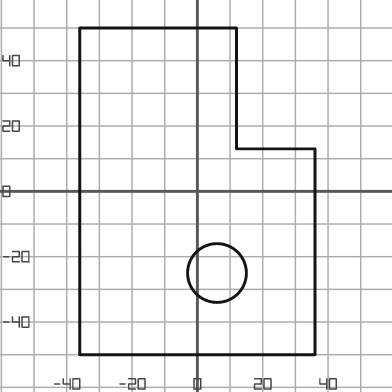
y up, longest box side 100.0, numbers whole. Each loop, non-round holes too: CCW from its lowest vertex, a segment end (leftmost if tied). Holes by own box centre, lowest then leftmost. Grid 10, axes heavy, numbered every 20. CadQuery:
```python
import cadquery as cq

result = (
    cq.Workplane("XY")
    .moveTo(-36.0, -50.0)
    .lineTo(36.0, -50.0)
    .lineTo(36.0, 13.0)
    .lineTo(12.0, 13.0)
    .lineTo(12.0, 50.0)
    .lineTo(-36.0, 50.0)
    .close()
    .moveTo(6.0, -25.0)
    .circle(9.0)
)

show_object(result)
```